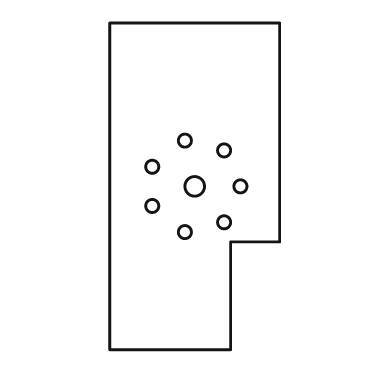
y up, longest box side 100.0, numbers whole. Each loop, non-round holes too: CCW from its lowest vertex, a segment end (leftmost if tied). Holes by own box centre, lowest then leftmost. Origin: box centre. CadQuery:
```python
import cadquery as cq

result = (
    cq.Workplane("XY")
    .moveTo(-26.0, -50.0)
    .lineTo(11.0, -50.0)
    .lineTo(11.0, -17.0)
    .lineTo(26.0, -17.0)
    .lineTo(26.0, 50.0)
    .lineTo(-26.0, 50.0)
    .close()
    .moveTo(-3.0, -14.0)
    .circle(2.0)
    .moveTo(9.0, -11.0)
    .circle(2.0)
    .moveTo(-13.0, -6.0)
    .circle(2.0)
    .moveTo(0.0, 0.0)
    .circle(3.0)
    .moveTo(14.0, 0.0)
    .circle(2.0)
    .moveTo(-13.0, 6.0)
    .circle(2.0)
    .moveTo(9.0, 11.0)
    .circle(2.0)
    .moveTo(-3.0, 14.0)
    .circle(2.0)
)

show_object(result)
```